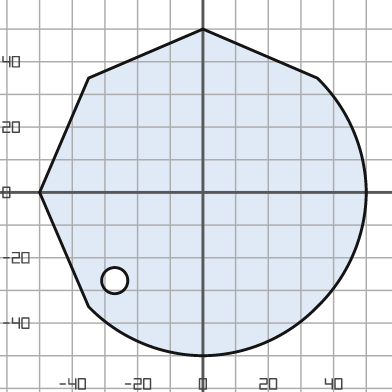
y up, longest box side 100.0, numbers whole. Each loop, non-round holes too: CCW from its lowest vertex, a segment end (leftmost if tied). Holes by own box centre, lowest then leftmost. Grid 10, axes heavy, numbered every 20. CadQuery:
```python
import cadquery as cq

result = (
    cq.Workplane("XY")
    .moveTo(0.0, -50.0)
    .threePointArc((19.0, -46.0), (35.0, -35.0))
    .threePointArc((46.0, -19.0), (50.0, 0.0))
    .threePointArc((46.0, 19.0), (35.0, 35.0))
    .lineTo(0.0, 50.0)
    .lineTo(-35.0, 35.0)
    .lineTo(-50.0, 0.0)
    .lineTo(-35.0, -35.0)
    .threePointArc((-19.0, -46.0), (0.0, -50.0))
    .close()
    .moveTo(-27.0, -27.0)
    .circle(4.0)
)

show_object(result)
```